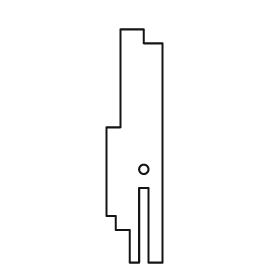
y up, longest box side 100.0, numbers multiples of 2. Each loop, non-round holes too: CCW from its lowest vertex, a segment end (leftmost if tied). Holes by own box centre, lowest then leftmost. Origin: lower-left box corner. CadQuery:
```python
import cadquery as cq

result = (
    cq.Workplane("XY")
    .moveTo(10.0, 0.0)
    .lineTo(14.0, 0.0)
    .lineTo(14.0, 32.0)
    .lineTo(18.0, 32.0)
    .lineTo(18.0, 0.0)
    .lineTo(24.0, 0.0)
    .lineTo(24.0, 94.0)
    .lineTo(16.0, 94.0)
    .lineTo(16.0, 100.0)
    .lineTo(6.0, 100.0)
    .lineTo(6.0, 58.0)
    .lineTo(0.0, 58.0)
    .lineTo(0.0, 20.0)
    .lineTo(4.0, 20.0)
    .lineTo(4.0, 14.0)
    .lineTo(10.0, 14.0)
    .close()
    .moveTo(16.0, 40.0)
    .circle(2.0)
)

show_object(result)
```